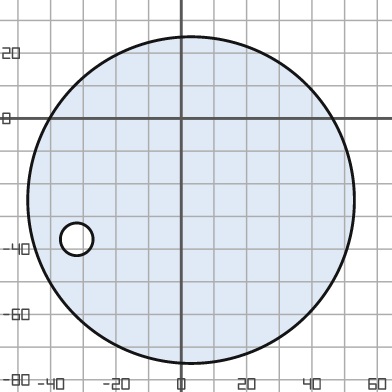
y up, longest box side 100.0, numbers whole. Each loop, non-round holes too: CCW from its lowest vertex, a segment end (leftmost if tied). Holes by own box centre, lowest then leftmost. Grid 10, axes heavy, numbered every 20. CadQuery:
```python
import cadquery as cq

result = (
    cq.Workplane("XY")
    .moveTo(3.0, -25.0)
    .circle(50.0)
    .moveTo(-32.0, -37.0)
    .circle(5.0)
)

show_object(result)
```